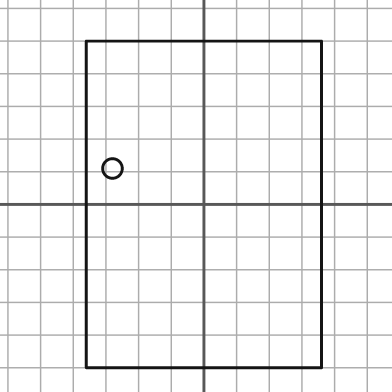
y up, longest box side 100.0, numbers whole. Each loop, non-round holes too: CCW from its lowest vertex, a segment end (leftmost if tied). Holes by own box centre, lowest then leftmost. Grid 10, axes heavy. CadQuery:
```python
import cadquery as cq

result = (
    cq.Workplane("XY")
    .moveTo(-36.0, -50.0)
    .lineTo(36.0, -50.0)
    .lineTo(36.0, 50.0)
    .lineTo(-36.0, 50.0)
    .close()
    .moveTo(-28.0, 11.0)
    .circle(3.0)
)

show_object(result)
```